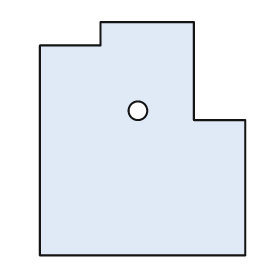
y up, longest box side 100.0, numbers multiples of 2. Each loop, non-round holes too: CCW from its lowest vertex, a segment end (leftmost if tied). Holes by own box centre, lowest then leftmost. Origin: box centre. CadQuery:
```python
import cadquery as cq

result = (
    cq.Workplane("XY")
    .moveTo(-44.0, -50.0)
    .lineTo(44.0, -50.0)
    .lineTo(44.0, 8.0)
    .lineTo(22.0, 8.0)
    .lineTo(22.0, 50.0)
    .lineTo(-18.0, 50.0)
    .lineTo(-18.0, 40.0)
    .lineTo(-44.0, 40.0)
    .close()
    .moveTo(-2.0, 12.0)
    .circle(4.0)
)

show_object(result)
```